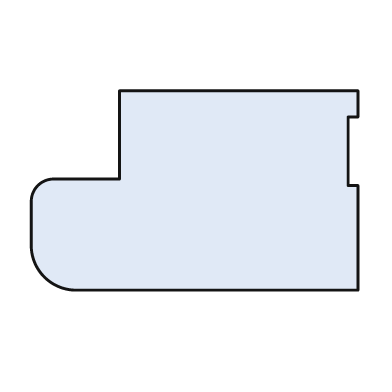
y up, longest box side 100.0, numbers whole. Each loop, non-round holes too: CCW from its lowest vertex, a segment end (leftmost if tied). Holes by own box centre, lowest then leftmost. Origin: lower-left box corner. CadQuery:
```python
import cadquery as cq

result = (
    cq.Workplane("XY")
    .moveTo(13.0, 0.0)
    .lineTo(100.0, 0.0)
    .lineTo(100.0, 32.0)
    .lineTo(97.0, 32.0)
    .lineTo(97.0, 53.0)
    .lineTo(100.0, 53.0)
    .lineTo(100.0, 61.0)
    .lineTo(27.0, 61.0)
    .lineTo(27.0, 34.0)
    .lineTo(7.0, 34.0)
    .threePointArc((2.0, 32.0), (0.0, 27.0))
    .lineTo(0.0, 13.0)
    .threePointArc((4.0, 4.0), (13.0, 0.0))
    .close()
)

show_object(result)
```